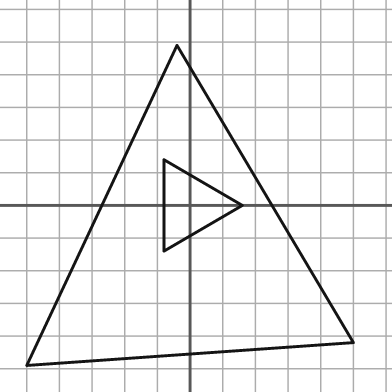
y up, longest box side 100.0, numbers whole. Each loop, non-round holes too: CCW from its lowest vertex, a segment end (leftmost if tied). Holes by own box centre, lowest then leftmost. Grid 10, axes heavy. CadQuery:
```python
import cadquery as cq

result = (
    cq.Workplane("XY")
    .moveTo(-50.0, -49.0)
    .lineTo(50.0, -42.0)
    .lineTo(-4.0, 49.0)
    .close()
    .moveTo(-8.0, -14.0)
    .lineTo(16.0, 0.0)
    .lineTo(-8.0, 14.0)
    .close()
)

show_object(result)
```